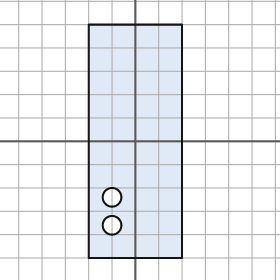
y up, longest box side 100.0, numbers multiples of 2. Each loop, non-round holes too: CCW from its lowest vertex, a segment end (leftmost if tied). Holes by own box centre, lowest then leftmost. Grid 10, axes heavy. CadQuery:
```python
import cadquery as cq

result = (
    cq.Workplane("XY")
    .moveTo(-20.0, -50.0)
    .lineTo(20.0, -50.0)
    .lineTo(20.0, 50.0)
    .lineTo(-20.0, 50.0)
    .close()
    .moveTo(-10.0, -36.0)
    .circle(4.0)
    .moveTo(-10.0, -24.0)
    .circle(4.0)
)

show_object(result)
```